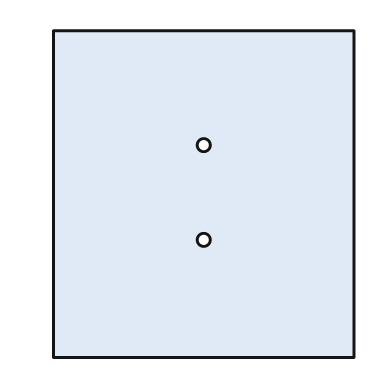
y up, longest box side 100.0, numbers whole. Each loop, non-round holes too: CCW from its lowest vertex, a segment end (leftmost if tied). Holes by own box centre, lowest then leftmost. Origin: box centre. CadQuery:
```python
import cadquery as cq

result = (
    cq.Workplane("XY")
    .moveTo(-46.0, -50.0)
    .lineTo(46.0, -50.0)
    .lineTo(46.0, 50.0)
    .lineTo(-46.0, 50.0)
    .close()
    .moveTo(0.0, -14.0)
    .circle(2.0)
    .moveTo(0.0, 15.0)
    .circle(2.0)
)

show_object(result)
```